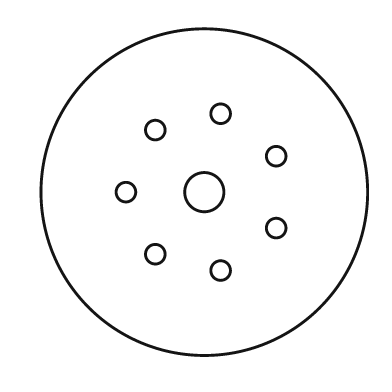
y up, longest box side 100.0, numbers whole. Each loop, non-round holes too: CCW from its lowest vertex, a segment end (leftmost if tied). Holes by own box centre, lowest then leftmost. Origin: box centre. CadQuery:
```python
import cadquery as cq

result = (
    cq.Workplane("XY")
    .moveTo(0.0, 0.0)
    .circle(50.0)
    .moveTo(5.0, -24.0)
    .circle(3.0)
    .moveTo(-15.0, -19.0)
    .circle(3.0)
    .moveTo(22.0, -11.0)
    .circle(3.0)
    .moveTo(-24.0, 0.0)
    .circle(3.0)
    .moveTo(0.0, 0.0)
    .circle(6.0)
    .moveTo(22.0, 11.0)
    .circle(3.0)
    .moveTo(-15.0, 19.0)
    .circle(3.0)
    .moveTo(5.0, 24.0)
    .circle(3.0)
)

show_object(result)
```